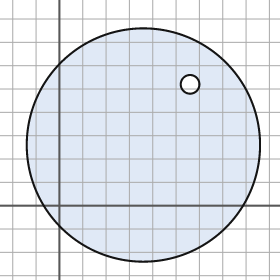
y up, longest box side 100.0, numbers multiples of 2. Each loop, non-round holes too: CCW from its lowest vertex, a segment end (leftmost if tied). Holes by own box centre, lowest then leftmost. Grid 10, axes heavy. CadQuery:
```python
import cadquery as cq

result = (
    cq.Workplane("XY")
    .moveTo(36.0, 26.0)
    .circle(50.0)
    .moveTo(56.0, 52.0)
    .circle(4.0)
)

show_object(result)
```